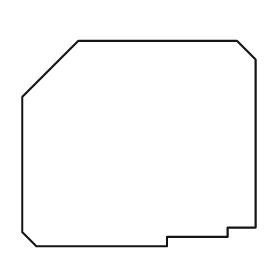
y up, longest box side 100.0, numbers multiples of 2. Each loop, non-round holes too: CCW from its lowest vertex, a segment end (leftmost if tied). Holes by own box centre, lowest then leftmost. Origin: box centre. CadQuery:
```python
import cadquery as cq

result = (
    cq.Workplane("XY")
    .moveTo(-44.0, -44.0)
    .lineTo(12.0, -44.0)
    .lineTo(12.0, -40.0)
    .lineTo(38.0, -40.0)
    .lineTo(38.0, -36.0)
    .lineTo(50.0, -36.0)
    .lineTo(50.0, 36.0)
    .lineTo(42.0, 44.0)
    .lineTo(-26.0, 44.0)
    .lineTo(-50.0, 20.0)
    .lineTo(-50.0, -38.0)
    .close()
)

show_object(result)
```